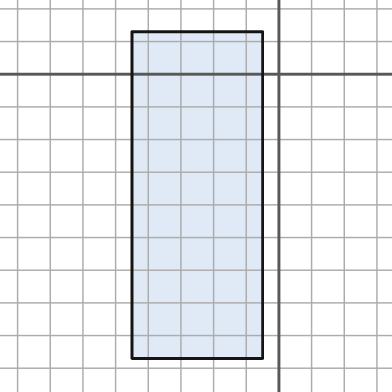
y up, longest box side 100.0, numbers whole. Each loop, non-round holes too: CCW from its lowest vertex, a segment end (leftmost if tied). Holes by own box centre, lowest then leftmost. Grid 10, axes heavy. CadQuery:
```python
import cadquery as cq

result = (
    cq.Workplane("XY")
    .moveTo(-45.0, -87.0)
    .lineTo(-5.0, -87.0)
    .lineTo(-5.0, 13.0)
    .lineTo(-45.0, 13.0)
    .close()
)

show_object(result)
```